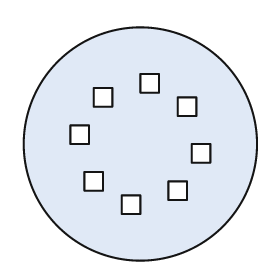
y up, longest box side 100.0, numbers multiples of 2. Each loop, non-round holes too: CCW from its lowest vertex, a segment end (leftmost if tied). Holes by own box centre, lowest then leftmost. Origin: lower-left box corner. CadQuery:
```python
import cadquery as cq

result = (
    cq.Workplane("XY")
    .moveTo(50.0, 50.0)
    .circle(50.0)
    .moveTo(42.0, 20.0)
    .lineTo(50.0, 20.0)
    .lineTo(50.0, 28.0)
    .lineTo(42.0, 28.0)
    .close()
    .moveTo(62.0, 26.0)
    .lineTo(70.0, 26.0)
    .lineTo(70.0, 34.0)
    .lineTo(62.0, 34.0)
    .close()
    .moveTo(26.0, 30.0)
    .lineTo(34.0, 30.0)
    .lineTo(34.0, 38.0)
    .lineTo(26.0, 38.0)
    .close()
    .moveTo(72.0, 42.0)
    .lineTo(80.0, 42.0)
    .lineTo(80.0, 50.0)
    .lineTo(72.0, 50.0)
    .close()
    .moveTo(20.0, 50.0)
    .lineTo(28.0, 50.0)
    .lineTo(28.0, 58.0)
    .lineTo(20.0, 58.0)
    .close()
    .moveTo(66.0, 62.0)
    .lineTo(74.0, 62.0)
    .lineTo(74.0, 70.0)
    .lineTo(66.0, 70.0)
    .close()
    .moveTo(30.0, 66.0)
    .lineTo(38.0, 66.0)
    .lineTo(38.0, 74.0)
    .lineTo(30.0, 74.0)
    .close()
    .moveTo(50.0, 72.0)
    .lineTo(58.0, 72.0)
    .lineTo(58.0, 80.0)
    .lineTo(50.0, 80.0)
    .close()
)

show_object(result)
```